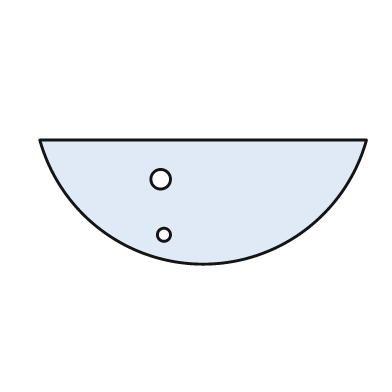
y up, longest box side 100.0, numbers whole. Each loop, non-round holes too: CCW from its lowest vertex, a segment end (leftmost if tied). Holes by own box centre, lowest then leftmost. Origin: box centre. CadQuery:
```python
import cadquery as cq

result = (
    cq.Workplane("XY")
    .moveTo(-50.0, 19.0)
    .threePointArc((0.0, -19.0), (50.0, 19.0))
    .close()
    .moveTo(-12.0, -10.0)
    .circle(2.0)
    .moveTo(-13.0, 7.0)
    .circle(3.0)
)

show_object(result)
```